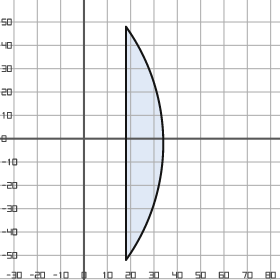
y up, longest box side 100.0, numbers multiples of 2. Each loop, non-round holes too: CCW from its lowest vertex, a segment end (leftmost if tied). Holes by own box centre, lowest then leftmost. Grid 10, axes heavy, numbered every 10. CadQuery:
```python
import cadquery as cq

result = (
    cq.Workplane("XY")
    .moveTo(18.0, -52.0)
    .threePointArc((34.0, -2.0), (18.0, 48.0))
    .close()
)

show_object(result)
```